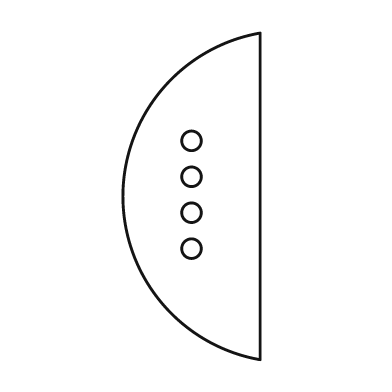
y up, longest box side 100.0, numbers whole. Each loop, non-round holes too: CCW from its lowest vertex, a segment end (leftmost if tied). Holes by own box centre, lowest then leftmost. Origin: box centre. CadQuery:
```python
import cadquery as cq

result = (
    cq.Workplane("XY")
    .moveTo(21.0, -50.0)
    .lineTo(21.0, 50.0)
    .threePointArc((-21.0, 0.0), (21.0, -50.0))
    .close()
    .moveTo(0.0, -16.0)
    .circle(3.0)
    .moveTo(0.0, -5.0)
    .circle(3.0)
    .moveTo(0.0, 6.0)
    .circle(3.0)
    .moveTo(0.0, 17.0)
    .circle(3.0)
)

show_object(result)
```